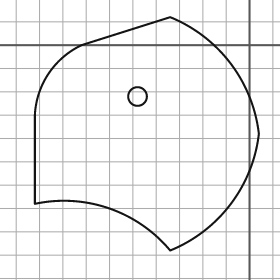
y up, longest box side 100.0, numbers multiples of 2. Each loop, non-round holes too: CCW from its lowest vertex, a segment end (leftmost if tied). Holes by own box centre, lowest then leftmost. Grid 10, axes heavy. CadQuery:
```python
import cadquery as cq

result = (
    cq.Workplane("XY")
    .moveTo(-34.0, -88.0)
    .threePointArc((-8.0, -68.0), (4.0, -38.0))
    .threePointArc((-8.0, -8.0), (-34.0, 12.0))
    .lineTo(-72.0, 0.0)
    .threePointArc((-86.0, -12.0), (-92.0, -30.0))
    .lineTo(-92.0, -68.0)
    .threePointArc((-60.0, -70.0), (-34.0, -88.0))
    .close()
    .moveTo(-48.0, -22.0)
    .circle(4.0)
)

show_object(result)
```